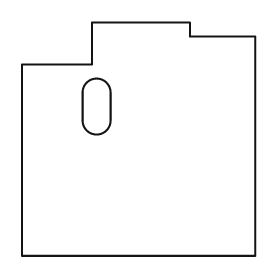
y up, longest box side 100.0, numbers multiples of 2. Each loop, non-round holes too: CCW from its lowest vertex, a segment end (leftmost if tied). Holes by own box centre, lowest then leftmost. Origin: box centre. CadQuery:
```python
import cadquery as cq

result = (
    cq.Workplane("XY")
    .moveTo(-50.0, -50.0)
    .lineTo(50.0, -50.0)
    .lineTo(50.0, 44.0)
    .lineTo(22.0, 44.0)
    .lineTo(22.0, 50.0)
    .lineTo(-20.0, 50.0)
    .lineTo(-20.0, 32.0)
    .lineTo(-50.0, 32.0)
    .close()
    .moveTo(-24.0, 8.0)
    .threePointArc((-18.0, 2.0), (-12.0, 8.0))
    .lineTo(-12.0, 20.0)
    .threePointArc((-18.0, 26.0), (-24.0, 20.0))
    .close()
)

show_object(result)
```